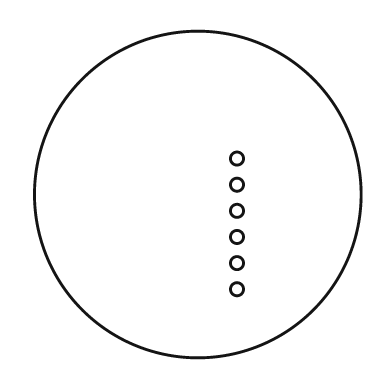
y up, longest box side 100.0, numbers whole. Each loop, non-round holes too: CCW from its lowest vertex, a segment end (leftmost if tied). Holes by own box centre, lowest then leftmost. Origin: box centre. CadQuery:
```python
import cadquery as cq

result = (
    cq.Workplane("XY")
    .moveTo(0.0, 0.0)
    .circle(50.0)
    .moveTo(12.0, -29.0)
    .circle(2.0)
    .moveTo(12.0, -21.0)
    .circle(2.0)
    .moveTo(12.0, -13.0)
    .circle(2.0)
    .moveTo(12.0, -5.0)
    .circle(2.0)
    .moveTo(12.0, 3.0)
    .circle(2.0)
    .moveTo(12.0, 11.0)
    .circle(2.0)
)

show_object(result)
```